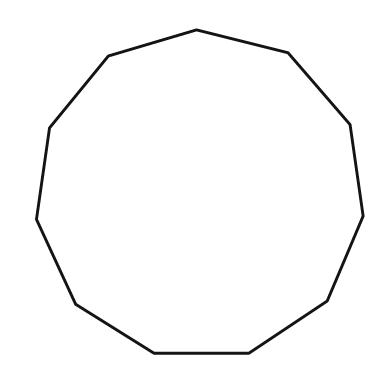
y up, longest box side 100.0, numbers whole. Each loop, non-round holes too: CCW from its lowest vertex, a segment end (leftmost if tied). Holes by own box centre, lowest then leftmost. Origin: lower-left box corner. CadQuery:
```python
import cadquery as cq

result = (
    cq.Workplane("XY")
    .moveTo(36.0, 0.0)
    .lineTo(65.0, 0.0)
    .lineTo(89.0, 16.0)
    .lineTo(100.0, 42.0)
    .lineTo(96.0, 70.0)
    .lineTo(77.0, 92.0)
    .lineTo(49.0, 99.0)
    .lineTo(22.0, 91.0)
    .lineTo(4.0, 69.0)
    .lineTo(0.0, 41.0)
    .lineTo(12.0, 15.0)
    .close()
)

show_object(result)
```